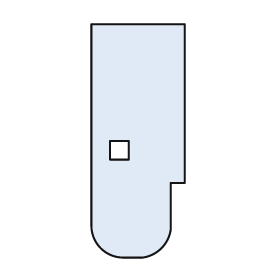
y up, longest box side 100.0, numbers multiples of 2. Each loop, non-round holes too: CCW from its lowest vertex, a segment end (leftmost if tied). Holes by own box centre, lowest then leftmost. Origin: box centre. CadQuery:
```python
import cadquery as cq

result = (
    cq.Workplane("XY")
    .moveTo(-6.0, -50.0)
    .lineTo(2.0, -50.0)
    .threePointArc((10.0, -46.0), (14.0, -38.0))
    .lineTo(14.0, -18.0)
    .lineTo(20.0, -18.0)
    .lineTo(20.0, 50.0)
    .lineTo(-20.0, 50.0)
    .lineTo(-20.0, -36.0)
    .threePointArc((-16.0, -46.0), (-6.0, -50.0))
    .close()
    .moveTo(-12.0, -8.0)
    .lineTo(-4.0, -8.0)
    .lineTo(-4.0, 0.0)
    .lineTo(-12.0, 0.0)
    .close()
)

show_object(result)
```